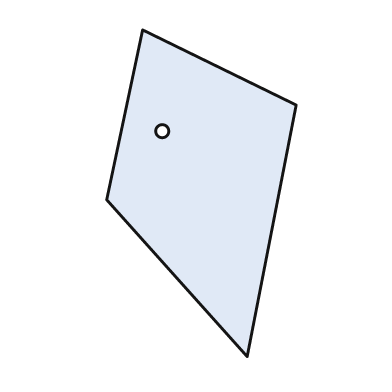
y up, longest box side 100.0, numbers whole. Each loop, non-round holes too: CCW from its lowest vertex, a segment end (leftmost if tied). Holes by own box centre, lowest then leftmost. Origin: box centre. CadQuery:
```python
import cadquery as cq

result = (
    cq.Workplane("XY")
    .moveTo(14.0, -50.0)
    .lineTo(29.0, 27.0)
    .lineTo(-18.0, 50.0)
    .lineTo(-29.0, -2.0)
    .close()
    .moveTo(-12.0, 19.0)
    .circle(2.0)
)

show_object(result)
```